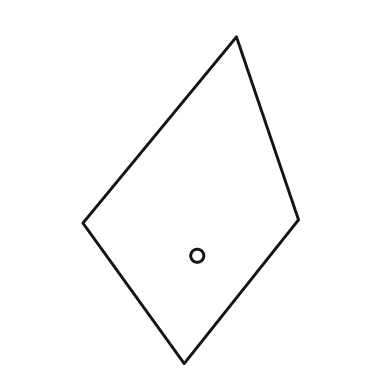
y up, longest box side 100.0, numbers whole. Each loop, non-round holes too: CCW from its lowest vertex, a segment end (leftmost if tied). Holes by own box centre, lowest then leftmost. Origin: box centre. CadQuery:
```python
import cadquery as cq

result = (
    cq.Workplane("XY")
    .moveTo(-2.0, -50.0)
    .lineTo(33.0, -6.0)
    .lineTo(14.0, 50.0)
    .lineTo(-33.0, -7.0)
    .close()
    .moveTo(2.0, -17.0)
    .circle(2.0)
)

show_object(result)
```